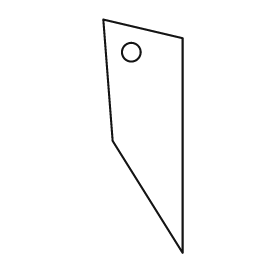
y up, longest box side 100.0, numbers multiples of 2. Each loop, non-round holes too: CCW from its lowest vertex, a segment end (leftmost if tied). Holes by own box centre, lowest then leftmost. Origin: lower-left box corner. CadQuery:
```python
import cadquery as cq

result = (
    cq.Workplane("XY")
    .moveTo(34.0, 0.0)
    .lineTo(34.0, 92.0)
    .lineTo(0.0, 100.0)
    .lineTo(4.0, 48.0)
    .close()
    .moveTo(12.0, 86.0)
    .circle(4.0)
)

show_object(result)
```